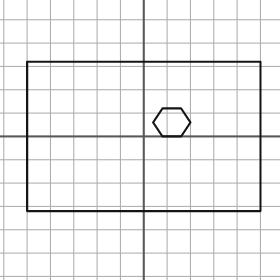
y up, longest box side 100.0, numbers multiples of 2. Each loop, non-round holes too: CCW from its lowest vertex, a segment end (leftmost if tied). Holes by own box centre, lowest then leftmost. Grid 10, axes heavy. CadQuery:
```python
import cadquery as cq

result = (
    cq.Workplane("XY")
    .moveTo(-50.0, -32.0)
    .lineTo(50.0, -32.0)
    .lineTo(50.0, 32.0)
    .lineTo(-50.0, 32.0)
    .close()
    .moveTo(8.0, 0.0)
    .lineTo(16.0, 0.0)
    .lineTo(20.0, 6.0)
    .lineTo(16.0, 12.0)
    .lineTo(8.0, 12.0)
    .lineTo(4.0, 6.0)
    .close()
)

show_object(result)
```